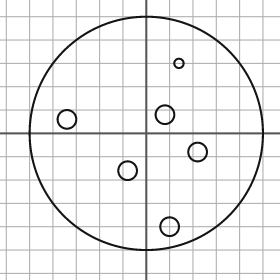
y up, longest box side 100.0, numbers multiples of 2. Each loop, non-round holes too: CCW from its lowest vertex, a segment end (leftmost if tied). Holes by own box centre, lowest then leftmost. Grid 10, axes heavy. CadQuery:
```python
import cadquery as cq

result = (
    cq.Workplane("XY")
    .moveTo(0.0, 0.0)
    .circle(50.0)
    .moveTo(10.0, -40.0)
    .circle(4.0)
    .moveTo(-8.0, -16.0)
    .circle(4.0)
    .moveTo(22.0, -8.0)
    .circle(4.0)
    .moveTo(-34.0, 6.0)
    .circle(4.0)
    .moveTo(8.0, 8.0)
    .circle(4.0)
    .moveTo(14.0, 30.0)
    .circle(2.0)
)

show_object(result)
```